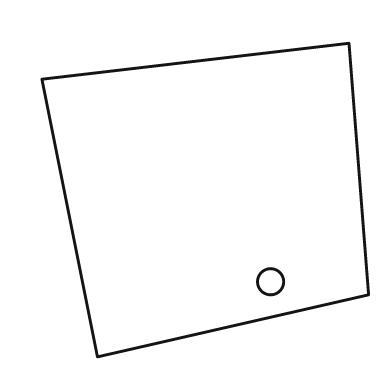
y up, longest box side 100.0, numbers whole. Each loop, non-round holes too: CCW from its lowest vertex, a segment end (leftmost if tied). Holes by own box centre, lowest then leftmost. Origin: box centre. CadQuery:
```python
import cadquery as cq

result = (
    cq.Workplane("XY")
    .moveTo(-33.0, -48.0)
    .lineTo(50.0, -29.0)
    .lineTo(44.0, 48.0)
    .lineTo(-50.0, 37.0)
    .close()
    .moveTo(20.0, -25.0)
    .circle(4.0)
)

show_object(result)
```